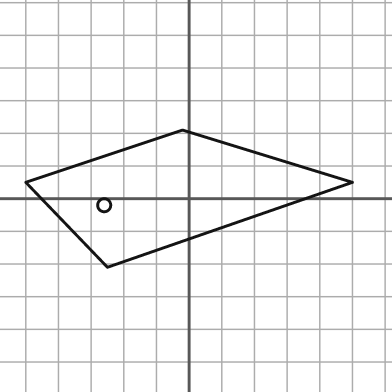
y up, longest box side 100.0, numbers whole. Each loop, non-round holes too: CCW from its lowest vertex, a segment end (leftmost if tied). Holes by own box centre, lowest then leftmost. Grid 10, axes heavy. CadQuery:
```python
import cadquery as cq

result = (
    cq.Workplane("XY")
    .moveTo(-25.0, -21.0)
    .lineTo(50.0, 5.0)
    .lineTo(-2.0, 21.0)
    .lineTo(-50.0, 5.0)
    .close()
    .moveTo(-26.0, -2.0)
    .circle(2.0)
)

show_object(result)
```